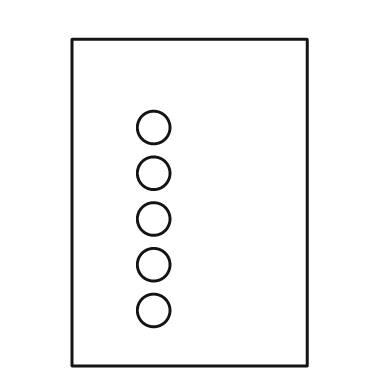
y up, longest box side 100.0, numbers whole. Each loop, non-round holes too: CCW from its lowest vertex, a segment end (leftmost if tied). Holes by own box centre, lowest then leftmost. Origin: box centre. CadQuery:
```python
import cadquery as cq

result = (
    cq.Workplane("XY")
    .moveTo(-36.0, -50.0)
    .lineTo(36.0, -50.0)
    .lineTo(36.0, 50.0)
    .lineTo(-36.0, 50.0)
    .close()
    .moveTo(-11.0, -33.0)
    .circle(5.0)
    .moveTo(-11.0, -19.0)
    .circle(5.0)
    .moveTo(-11.0, -5.0)
    .circle(5.0)
    .moveTo(-11.0, 9.0)
    .circle(5.0)
    .moveTo(-11.0, 23.0)
    .circle(5.0)
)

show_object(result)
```